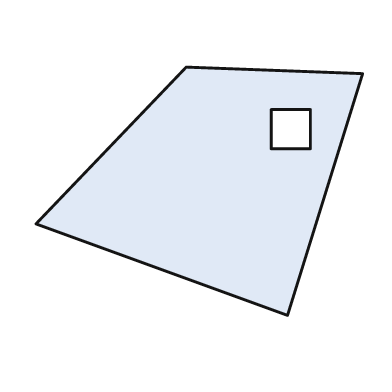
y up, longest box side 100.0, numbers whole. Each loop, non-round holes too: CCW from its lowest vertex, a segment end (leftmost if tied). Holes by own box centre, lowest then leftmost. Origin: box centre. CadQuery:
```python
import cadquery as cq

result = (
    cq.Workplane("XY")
    .moveTo(27.0, -38.0)
    .lineTo(50.0, 36.0)
    .lineTo(-4.0, 38.0)
    .lineTo(-50.0, -10.0)
    .close()
    .moveTo(22.0, 13.0)
    .lineTo(34.0, 13.0)
    .lineTo(34.0, 25.0)
    .lineTo(22.0, 25.0)
    .close()
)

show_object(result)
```